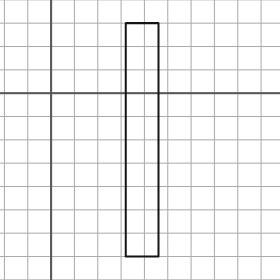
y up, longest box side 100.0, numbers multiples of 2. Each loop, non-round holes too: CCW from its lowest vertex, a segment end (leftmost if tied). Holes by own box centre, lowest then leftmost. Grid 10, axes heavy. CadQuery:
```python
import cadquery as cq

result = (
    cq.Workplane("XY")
    .moveTo(32.0, -70.0)
    .lineTo(46.0, -70.0)
    .lineTo(46.0, 30.0)
    .lineTo(32.0, 30.0)
    .close()
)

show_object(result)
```